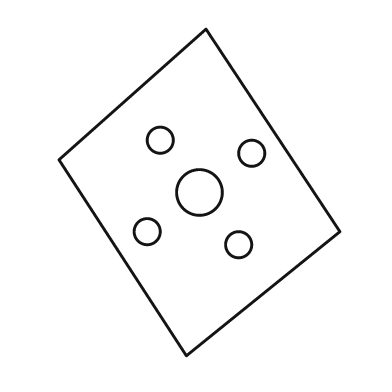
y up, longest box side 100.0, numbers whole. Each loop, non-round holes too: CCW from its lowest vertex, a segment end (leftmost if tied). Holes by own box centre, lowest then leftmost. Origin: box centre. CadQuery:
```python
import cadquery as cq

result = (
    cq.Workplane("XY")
    .moveTo(-4.0, -50.0)
    .lineTo(43.0, -12.0)
    .lineTo(2.0, 50.0)
    .lineTo(-43.0, 10.0)
    .close()
    .moveTo(12.0, -16.0)
    .circle(4.0)
    .moveTo(-16.0, -12.0)
    .circle(4.0)
    .moveTo(0.0, 0.0)
    .circle(7.0)
    .moveTo(16.0, 12.0)
    .circle(4.0)
    .moveTo(-12.0, 16.0)
    .circle(4.0)
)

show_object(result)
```